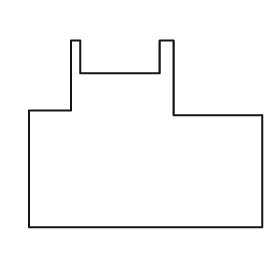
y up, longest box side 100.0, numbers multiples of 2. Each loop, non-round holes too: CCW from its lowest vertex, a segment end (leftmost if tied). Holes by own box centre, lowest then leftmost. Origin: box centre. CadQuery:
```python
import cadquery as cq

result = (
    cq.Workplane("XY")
    .moveTo(-50.0, -40.0)
    .lineTo(50.0, -40.0)
    .lineTo(50.0, 8.0)
    .lineTo(12.0, 8.0)
    .lineTo(12.0, 40.0)
    .lineTo(6.0, 40.0)
    .lineTo(6.0, 26.0)
    .lineTo(-28.0, 26.0)
    .lineTo(-28.0, 40.0)
    .lineTo(-32.0, 40.0)
    .lineTo(-32.0, 10.0)
    .lineTo(-50.0, 10.0)
    .close()
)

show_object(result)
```